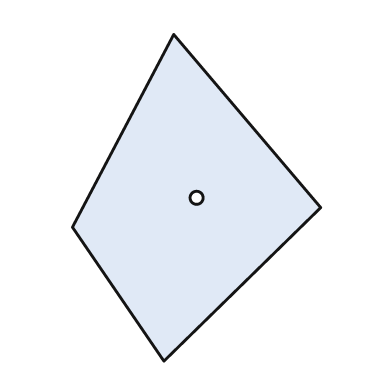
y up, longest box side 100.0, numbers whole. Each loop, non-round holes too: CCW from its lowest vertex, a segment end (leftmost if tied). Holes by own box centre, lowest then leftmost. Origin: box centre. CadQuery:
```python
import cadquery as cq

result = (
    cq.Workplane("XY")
    .moveTo(-10.0, -50.0)
    .lineTo(38.0, -3.0)
    .lineTo(-7.0, 50.0)
    .lineTo(-38.0, -9.0)
    .close()
    .moveTo(0.0, 0.0)
    .circle(2.0)
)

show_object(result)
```